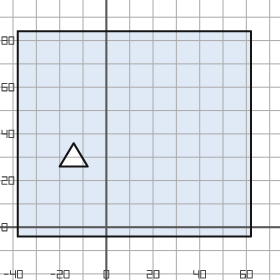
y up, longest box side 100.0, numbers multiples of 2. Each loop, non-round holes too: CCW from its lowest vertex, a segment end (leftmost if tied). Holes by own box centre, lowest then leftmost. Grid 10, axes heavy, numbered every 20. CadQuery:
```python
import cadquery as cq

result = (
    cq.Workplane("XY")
    .moveTo(-38.0, -4.0)
    .lineTo(62.0, -4.0)
    .lineTo(62.0, 84.0)
    .lineTo(-38.0, 84.0)
    .close()
    .moveTo(-20.0, 26.0)
    .lineTo(-8.0, 26.0)
    .lineTo(-14.0, 36.0)
    .close()
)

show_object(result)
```